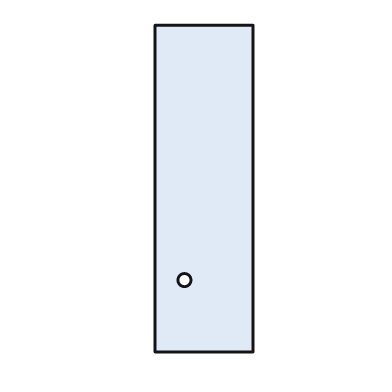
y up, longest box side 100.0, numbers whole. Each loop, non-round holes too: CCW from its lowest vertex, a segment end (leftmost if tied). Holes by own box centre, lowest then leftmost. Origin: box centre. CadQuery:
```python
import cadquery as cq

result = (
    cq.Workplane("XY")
    .moveTo(-15.0, -50.0)
    .lineTo(15.0, -50.0)
    .lineTo(15.0, 50.0)
    .lineTo(-15.0, 50.0)
    .close()
    .moveTo(-6.0, -28.0)
    .circle(2.0)
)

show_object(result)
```